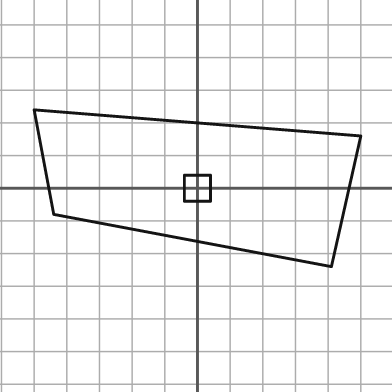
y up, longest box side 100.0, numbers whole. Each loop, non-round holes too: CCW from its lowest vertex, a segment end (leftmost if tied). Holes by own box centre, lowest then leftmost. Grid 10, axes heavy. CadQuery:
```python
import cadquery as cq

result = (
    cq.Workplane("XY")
    .moveTo(41.0, -24.0)
    .lineTo(50.0, 16.0)
    .lineTo(-50.0, 24.0)
    .lineTo(-44.0, -8.0)
    .close()
    .moveTo(-4.0, -4.0)
    .lineTo(4.0, -4.0)
    .lineTo(4.0, 4.0)
    .lineTo(-4.0, 4.0)
    .close()
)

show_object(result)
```